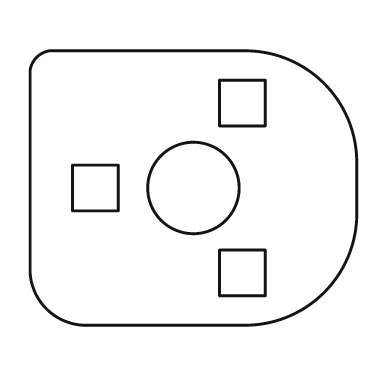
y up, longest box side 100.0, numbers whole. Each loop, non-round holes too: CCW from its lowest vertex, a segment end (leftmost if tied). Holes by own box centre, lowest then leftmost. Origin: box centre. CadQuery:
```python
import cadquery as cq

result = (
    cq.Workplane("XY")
    .moveTo(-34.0, -42.0)
    .lineTo(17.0, -42.0)
    .threePointArc((40.0, -32.0), (50.0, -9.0))
    .lineTo(50.0, 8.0)
    .threePointArc((40.0, 32.0), (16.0, 42.0))
    .lineTo(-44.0, 42.0)
    .threePointArc((-48.0, 40.0), (-50.0, 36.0))
    .lineTo(-50.0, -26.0)
    .threePointArc((-45.0, -37.0), (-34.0, -42.0))
    .close()
    .moveTo(8.0, -33.0)
    .lineTo(22.0, -33.0)
    .lineTo(22.0, -19.0)
    .lineTo(8.0, -19.0)
    .close()
    .moveTo(-37.0, -7.0)
    .lineTo(-23.0, -7.0)
    .lineTo(-23.0, 7.0)
    .lineTo(-37.0, 7.0)
    .close()
    .moveTo(0.0, 0.0)
    .circle(14.0)
    .moveTo(8.0, 19.0)
    .lineTo(22.0, 19.0)
    .lineTo(22.0, 33.0)
    .lineTo(8.0, 33.0)
    .close()
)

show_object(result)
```